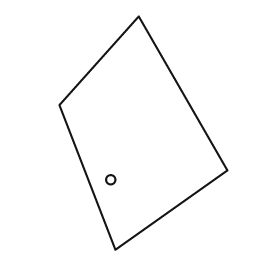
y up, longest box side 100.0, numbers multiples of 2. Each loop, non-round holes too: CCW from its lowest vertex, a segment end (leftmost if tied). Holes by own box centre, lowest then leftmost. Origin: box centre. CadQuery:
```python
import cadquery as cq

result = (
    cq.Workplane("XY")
    .moveTo(-12.0, -50.0)
    .lineTo(36.0, -16.0)
    .lineTo(-2.0, 50.0)
    .lineTo(-36.0, 12.0)
    .close()
    .moveTo(-14.0, -20.0)
    .circle(2.0)
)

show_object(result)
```